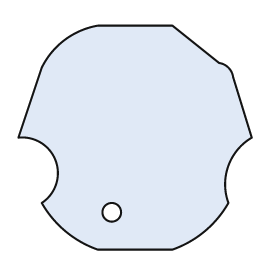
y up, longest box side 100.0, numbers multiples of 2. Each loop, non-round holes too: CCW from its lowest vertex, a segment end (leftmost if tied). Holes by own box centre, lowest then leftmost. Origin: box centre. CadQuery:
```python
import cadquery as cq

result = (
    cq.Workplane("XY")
    .moveTo(-16.0, -48.0)
    .lineTo(16.0, -48.0)
    .threePointArc((30.0, -40.0), (40.0, -28.0))
    .threePointArc((40.0, -12.0), (50.0, 0.0))
    .lineTo(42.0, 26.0)
    .threePointArc((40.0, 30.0), (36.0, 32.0))
    .lineTo(16.0, 48.0)
    .lineTo(-16.0, 48.0)
    .threePointArc((-30.0, 42.0), (-40.0, 30.0))
    .lineTo(-50.0, 0.0)
    .threePointArc((-34.0, -10.0), (-40.0, -28.0))
    .threePointArc((-30.0, -40.0), (-16.0, -48.0))
    .close()
    .moveTo(-10.0, -32.0)
    .circle(4.0)
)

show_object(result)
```